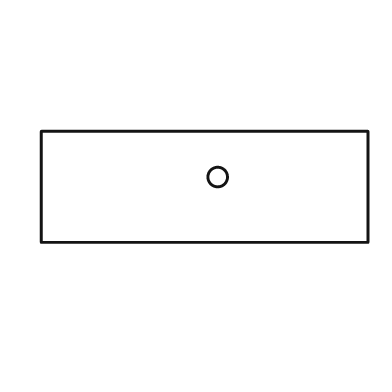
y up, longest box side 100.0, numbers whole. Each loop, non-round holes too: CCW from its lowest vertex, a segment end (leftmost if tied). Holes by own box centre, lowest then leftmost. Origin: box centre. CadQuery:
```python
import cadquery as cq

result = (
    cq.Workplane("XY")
    .moveTo(-50.0, -17.0)
    .lineTo(50.0, -17.0)
    .lineTo(50.0, 17.0)
    .lineTo(-50.0, 17.0)
    .close()
    .moveTo(4.0, 3.0)
    .circle(3.0)
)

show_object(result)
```